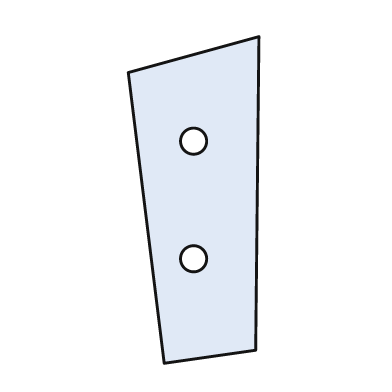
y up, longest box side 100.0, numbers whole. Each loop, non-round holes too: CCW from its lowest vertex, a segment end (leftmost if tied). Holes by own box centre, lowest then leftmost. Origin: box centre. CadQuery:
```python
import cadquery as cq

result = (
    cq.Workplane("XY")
    .moveTo(-9.0, -50.0)
    .lineTo(19.0, -46.0)
    .lineTo(20.0, 50.0)
    .lineTo(-20.0, 39.0)
    .close()
    .moveTo(0.0, -18.0)
    .circle(4.0)
    .moveTo(0.0, 18.0)
    .circle(4.0)
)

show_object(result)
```